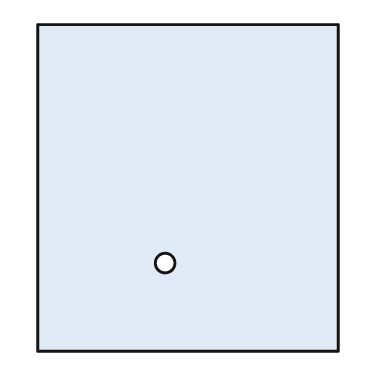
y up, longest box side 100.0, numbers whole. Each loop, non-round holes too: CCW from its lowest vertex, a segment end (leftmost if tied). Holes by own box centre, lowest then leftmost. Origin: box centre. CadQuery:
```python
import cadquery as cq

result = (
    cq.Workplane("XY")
    .moveTo(-46.0, -50.0)
    .lineTo(46.0, -50.0)
    .lineTo(46.0, 50.0)
    .lineTo(-46.0, 50.0)
    .close()
    .moveTo(-7.0, -23.0)
    .circle(3.0)
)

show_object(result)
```